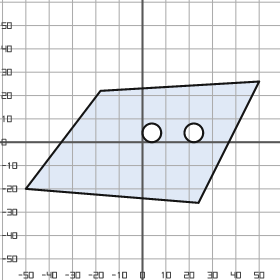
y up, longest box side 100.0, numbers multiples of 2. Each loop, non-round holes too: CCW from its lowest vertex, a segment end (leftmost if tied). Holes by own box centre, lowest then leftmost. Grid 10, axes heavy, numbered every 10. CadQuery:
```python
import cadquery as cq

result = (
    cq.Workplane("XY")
    .moveTo(24.0, -26.0)
    .lineTo(50.0, 26.0)
    .lineTo(-18.0, 22.0)
    .lineTo(-50.0, -20.0)
    .close()
    .moveTo(4.0, 4.0)
    .circle(4.0)
    .moveTo(22.0, 4.0)
    .circle(4.0)
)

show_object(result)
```